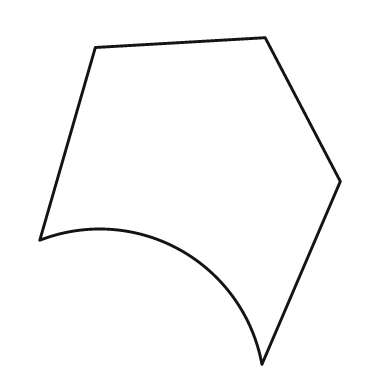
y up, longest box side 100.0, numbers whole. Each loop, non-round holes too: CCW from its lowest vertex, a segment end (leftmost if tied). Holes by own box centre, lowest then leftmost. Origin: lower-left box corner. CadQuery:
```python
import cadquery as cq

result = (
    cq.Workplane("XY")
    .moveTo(68.0, 0.0)
    .lineTo(92.0, 56.0)
    .lineTo(69.0, 100.0)
    .lineTo(17.0, 97.0)
    .lineTo(0.0, 38.0)
    .threePointArc((43.0, 35.0), (68.0, 0.0))
    .close()
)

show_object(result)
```